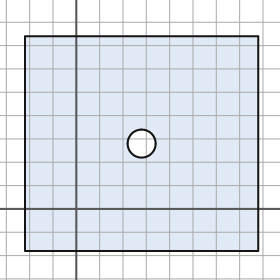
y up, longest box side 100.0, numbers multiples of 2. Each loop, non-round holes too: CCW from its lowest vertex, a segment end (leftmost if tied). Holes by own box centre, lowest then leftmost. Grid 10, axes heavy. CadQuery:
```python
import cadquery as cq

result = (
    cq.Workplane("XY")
    .moveTo(-22.0, -18.0)
    .lineTo(78.0, -18.0)
    .lineTo(78.0, 74.0)
    .lineTo(-22.0, 74.0)
    .close()
    .moveTo(28.0, 28.0)
    .circle(6.0)
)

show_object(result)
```